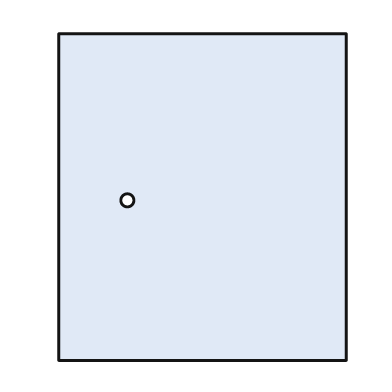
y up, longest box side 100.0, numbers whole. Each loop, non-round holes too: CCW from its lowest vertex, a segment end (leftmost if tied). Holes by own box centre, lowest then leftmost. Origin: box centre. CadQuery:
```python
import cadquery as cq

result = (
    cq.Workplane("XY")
    .moveTo(-44.0, -50.0)
    .lineTo(44.0, -50.0)
    .lineTo(44.0, 50.0)
    .lineTo(-44.0, 50.0)
    .close()
    .moveTo(-23.0, -1.0)
    .circle(2.0)
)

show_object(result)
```